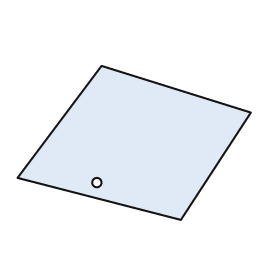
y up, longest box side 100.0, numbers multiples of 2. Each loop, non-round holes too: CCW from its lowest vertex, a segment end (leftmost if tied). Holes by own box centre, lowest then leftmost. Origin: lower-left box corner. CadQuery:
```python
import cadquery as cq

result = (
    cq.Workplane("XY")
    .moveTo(70.0, 0.0)
    .lineTo(100.0, 46.0)
    .lineTo(36.0, 66.0)
    .lineTo(0.0, 18.0)
    .close()
    .moveTo(34.0, 16.0)
    .circle(2.0)
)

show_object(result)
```